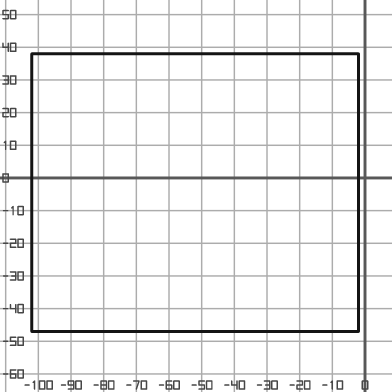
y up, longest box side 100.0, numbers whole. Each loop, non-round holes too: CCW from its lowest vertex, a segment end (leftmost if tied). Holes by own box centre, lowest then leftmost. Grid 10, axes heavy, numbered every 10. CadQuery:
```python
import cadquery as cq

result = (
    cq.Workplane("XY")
    .moveTo(-102.0, -47.0)
    .lineTo(-2.0, -47.0)
    .lineTo(-2.0, 38.0)
    .lineTo(-102.0, 38.0)
    .close()
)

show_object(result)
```